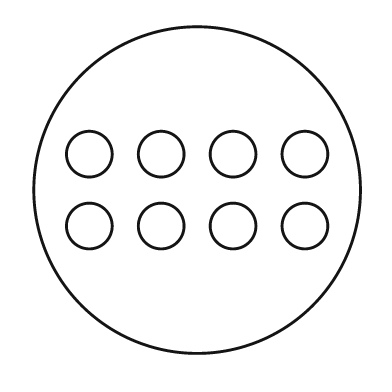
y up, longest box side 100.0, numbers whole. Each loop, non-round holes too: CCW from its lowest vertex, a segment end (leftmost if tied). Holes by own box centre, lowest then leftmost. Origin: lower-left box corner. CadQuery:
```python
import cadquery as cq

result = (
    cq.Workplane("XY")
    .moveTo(50.0, 50.0)
    .circle(50.0)
    .moveTo(17.0, 39.0)
    .circle(7.0)
    .moveTo(39.0, 39.0)
    .circle(7.0)
    .moveTo(61.0, 39.0)
    .circle(7.0)
    .moveTo(83.0, 39.0)
    .circle(7.0)
    .moveTo(17.0, 61.0)
    .circle(7.0)
    .moveTo(39.0, 61.0)
    .circle(7.0)
    .moveTo(61.0, 61.0)
    .circle(7.0)
    .moveTo(83.0, 61.0)
    .circle(7.0)
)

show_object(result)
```